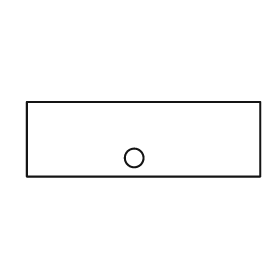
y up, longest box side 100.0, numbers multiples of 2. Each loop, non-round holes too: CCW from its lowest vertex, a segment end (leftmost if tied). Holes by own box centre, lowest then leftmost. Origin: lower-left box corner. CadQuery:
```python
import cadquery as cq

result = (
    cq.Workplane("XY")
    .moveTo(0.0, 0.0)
    .lineTo(100.0, 0.0)
    .lineTo(100.0, 32.0)
    .lineTo(0.0, 32.0)
    .close()
    .moveTo(46.0, 8.0)
    .circle(4.0)
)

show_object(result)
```